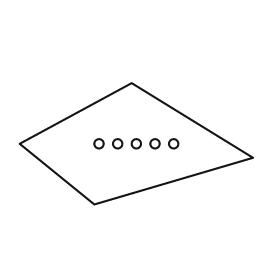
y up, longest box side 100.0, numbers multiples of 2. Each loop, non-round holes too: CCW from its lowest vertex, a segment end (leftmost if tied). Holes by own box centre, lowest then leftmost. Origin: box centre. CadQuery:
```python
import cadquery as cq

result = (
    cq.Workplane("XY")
    .moveTo(-18.0, -26.0)
    .lineTo(50.0, -6.0)
    .lineTo(-2.0, 26.0)
    .lineTo(-50.0, 0.0)
    .close()
    .moveTo(-16.0, 0.0)
    .circle(2.0)
    .moveTo(-8.0, 0.0)
    .circle(2.0)
    .moveTo(0.0, 0.0)
    .circle(2.0)
    .moveTo(8.0, 0.0)
    .circle(2.0)
    .moveTo(16.0, 0.0)
    .circle(2.0)
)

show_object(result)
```